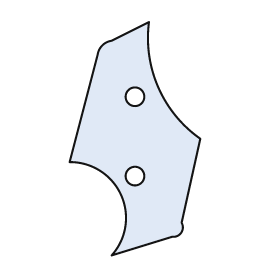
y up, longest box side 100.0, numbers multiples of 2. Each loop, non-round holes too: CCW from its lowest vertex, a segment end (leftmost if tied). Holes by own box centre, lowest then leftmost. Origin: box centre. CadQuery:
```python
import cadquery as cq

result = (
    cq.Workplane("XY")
    .moveTo(-10.0, -50.0)
    .lineTo(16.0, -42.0)
    .threePointArc((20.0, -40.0), (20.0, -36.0))
    .lineTo(28.0, 0.0)
    .threePointArc((10.0, 22.0), (6.0, 50.0))
    .lineTo(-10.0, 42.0)
    .threePointArc((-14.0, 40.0), (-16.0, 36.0))
    .lineTo(-28.0, -10.0)
    .threePointArc((-6.0, -24.0), (-10.0, -50.0))
    .close()
    .moveTo(0.0, -16.0)
    .circle(4.0)
    .moveTo(0.0, 18.0)
    .circle(4.0)
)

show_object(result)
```